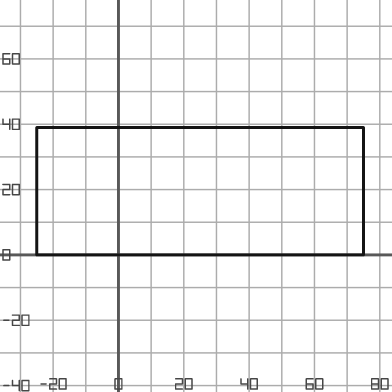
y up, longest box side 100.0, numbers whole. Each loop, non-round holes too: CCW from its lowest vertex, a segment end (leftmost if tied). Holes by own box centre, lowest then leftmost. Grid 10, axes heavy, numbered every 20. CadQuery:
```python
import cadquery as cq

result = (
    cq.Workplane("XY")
    .moveTo(-25.0, 0.0)
    .lineTo(75.0, 0.0)
    .lineTo(75.0, 39.0)
    .lineTo(-25.0, 39.0)
    .close()
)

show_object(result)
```